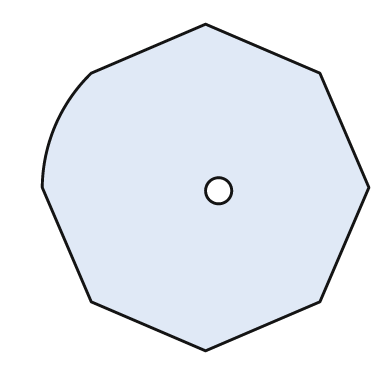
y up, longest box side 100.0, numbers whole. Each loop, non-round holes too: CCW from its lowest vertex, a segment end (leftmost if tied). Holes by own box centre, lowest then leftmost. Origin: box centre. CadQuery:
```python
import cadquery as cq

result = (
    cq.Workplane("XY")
    .moveTo(0.0, -50.0)
    .lineTo(35.0, -35.0)
    .lineTo(50.0, 0.0)
    .lineTo(35.0, 35.0)
    .lineTo(0.0, 50.0)
    .lineTo(-35.0, 35.0)
    .threePointArc((-46.0, 19.0), (-50.0, 0.0))
    .lineTo(-35.0, -35.0)
    .close()
    .moveTo(4.0, -1.0)
    .circle(4.0)
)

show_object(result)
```